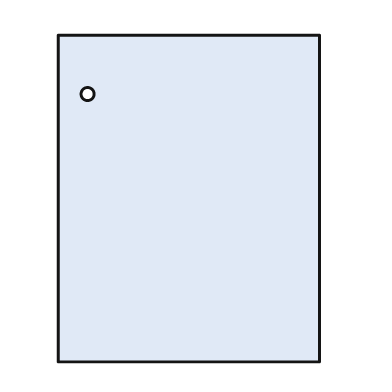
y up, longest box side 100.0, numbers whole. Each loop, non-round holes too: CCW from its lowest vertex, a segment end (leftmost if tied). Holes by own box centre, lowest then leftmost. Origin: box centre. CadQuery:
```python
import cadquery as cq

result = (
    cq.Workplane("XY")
    .moveTo(-40.0, -50.0)
    .lineTo(40.0, -50.0)
    .lineTo(40.0, 50.0)
    .lineTo(-40.0, 50.0)
    .close()
    .moveTo(-31.0, 32.0)
    .circle(2.0)
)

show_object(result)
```